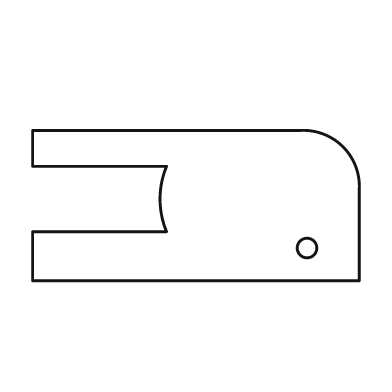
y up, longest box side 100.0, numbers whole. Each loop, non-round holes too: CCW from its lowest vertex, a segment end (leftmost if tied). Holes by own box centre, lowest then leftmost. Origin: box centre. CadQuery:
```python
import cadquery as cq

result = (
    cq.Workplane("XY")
    .moveTo(-50.0, -23.0)
    .lineTo(50.0, -23.0)
    .lineTo(50.0, 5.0)
    .threePointArc((45.0, 18.0), (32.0, 23.0))
    .lineTo(-50.0, 23.0)
    .lineTo(-50.0, 12.0)
    .lineTo(-9.0, 12.0)
    .threePointArc((-11.0, 2.0), (-9.0, -8.0))
    .lineTo(-50.0, -8.0)
    .close()
    .moveTo(34.0, -13.0)
    .circle(3.0)
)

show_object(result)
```